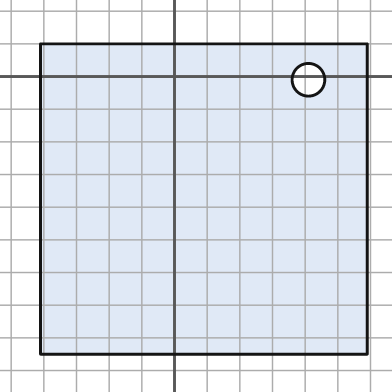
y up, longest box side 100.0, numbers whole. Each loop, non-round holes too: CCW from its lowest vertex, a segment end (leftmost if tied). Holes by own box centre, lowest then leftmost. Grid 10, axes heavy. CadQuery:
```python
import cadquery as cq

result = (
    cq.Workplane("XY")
    .moveTo(-41.0, -85.0)
    .lineTo(59.0, -85.0)
    .lineTo(59.0, 10.0)
    .lineTo(-41.0, 10.0)
    .close()
    .moveTo(41.0, -1.0)
    .circle(5.0)
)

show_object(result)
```